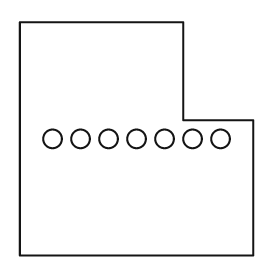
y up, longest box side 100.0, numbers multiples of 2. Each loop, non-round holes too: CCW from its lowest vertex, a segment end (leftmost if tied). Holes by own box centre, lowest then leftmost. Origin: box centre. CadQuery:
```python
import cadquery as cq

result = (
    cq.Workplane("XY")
    .moveTo(-50.0, -50.0)
    .lineTo(50.0, -50.0)
    .lineTo(50.0, 8.0)
    .lineTo(20.0, 8.0)
    .lineTo(20.0, 50.0)
    .lineTo(-50.0, 50.0)
    .close()
    .moveTo(-36.0, 0.0)
    .circle(4.0)
    .moveTo(-24.0, 0.0)
    .circle(4.0)
    .moveTo(-12.0, 0.0)
    .circle(4.0)
    .moveTo(0.0, 0.0)
    .circle(4.0)
    .moveTo(12.0, 0.0)
    .circle(4.0)
    .moveTo(24.0, 0.0)
    .circle(4.0)
    .moveTo(36.0, 0.0)
    .circle(4.0)
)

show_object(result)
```